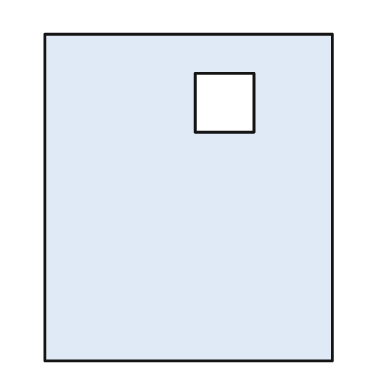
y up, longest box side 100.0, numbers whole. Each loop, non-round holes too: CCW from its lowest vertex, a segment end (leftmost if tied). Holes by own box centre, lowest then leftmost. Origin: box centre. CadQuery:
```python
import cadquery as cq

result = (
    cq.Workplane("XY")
    .moveTo(-44.0, -50.0)
    .lineTo(44.0, -50.0)
    .lineTo(44.0, 50.0)
    .lineTo(-44.0, 50.0)
    .close()
    .moveTo(2.0, 20.0)
    .lineTo(20.0, 20.0)
    .lineTo(20.0, 38.0)
    .lineTo(2.0, 38.0)
    .close()
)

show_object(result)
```